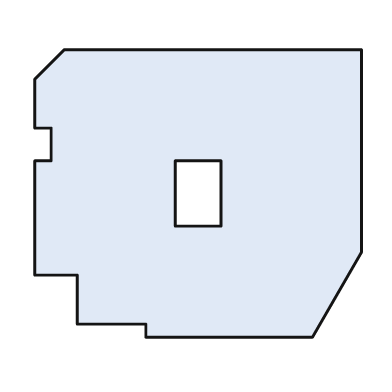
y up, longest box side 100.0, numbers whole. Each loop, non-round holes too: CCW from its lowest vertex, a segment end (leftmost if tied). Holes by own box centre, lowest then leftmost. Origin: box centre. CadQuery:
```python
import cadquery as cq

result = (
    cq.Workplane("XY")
    .moveTo(-16.0, -44.0)
    .lineTo(35.0, -44.0)
    .lineTo(50.0, -18.0)
    .lineTo(50.0, 44.0)
    .lineTo(-41.0, 44.0)
    .lineTo(-50.0, 35.0)
    .lineTo(-50.0, 20.0)
    .lineTo(-45.0, 20.0)
    .lineTo(-45.0, 10.0)
    .lineTo(-50.0, 10.0)
    .lineTo(-50.0, -25.0)
    .lineTo(-37.0, -25.0)
    .lineTo(-37.0, -40.0)
    .lineTo(-16.0, -40.0)
    .close()
    .moveTo(-7.0, -10.0)
    .lineTo(7.0, -10.0)
    .lineTo(7.0, 10.0)
    .lineTo(-7.0, 10.0)
    .close()
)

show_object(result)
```